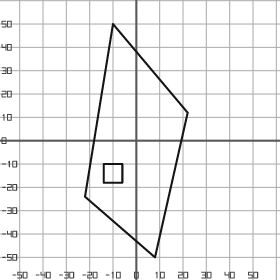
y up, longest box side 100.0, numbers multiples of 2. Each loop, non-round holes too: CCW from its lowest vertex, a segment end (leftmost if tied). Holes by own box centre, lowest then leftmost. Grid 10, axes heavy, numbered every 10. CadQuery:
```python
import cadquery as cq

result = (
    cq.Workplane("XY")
    .moveTo(8.0, -50.0)
    .lineTo(22.0, 12.0)
    .lineTo(-10.0, 50.0)
    .lineTo(-22.0, -24.0)
    .close()
    .moveTo(-14.0, -18.0)
    .lineTo(-6.0, -18.0)
    .lineTo(-6.0, -10.0)
    .lineTo(-14.0, -10.0)
    .close()
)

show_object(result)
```